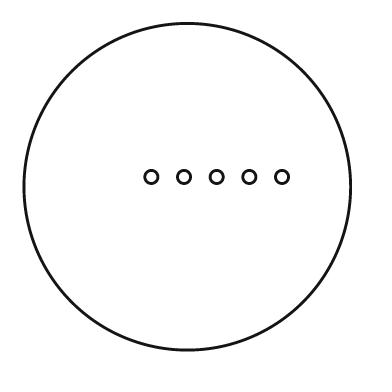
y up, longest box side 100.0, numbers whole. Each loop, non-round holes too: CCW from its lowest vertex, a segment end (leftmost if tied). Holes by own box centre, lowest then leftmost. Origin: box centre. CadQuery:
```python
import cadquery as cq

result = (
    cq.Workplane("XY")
    .moveTo(0.0, 0.0)
    .circle(50.0)
    .moveTo(-11.0, 3.0)
    .circle(2.0)
    .moveTo(-1.0, 3.0)
    .circle(2.0)
    .moveTo(9.0, 3.0)
    .circle(2.0)
    .moveTo(19.0, 3.0)
    .circle(2.0)
    .moveTo(29.0, 3.0)
    .circle(2.0)
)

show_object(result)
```